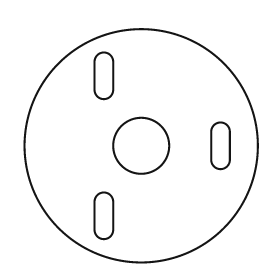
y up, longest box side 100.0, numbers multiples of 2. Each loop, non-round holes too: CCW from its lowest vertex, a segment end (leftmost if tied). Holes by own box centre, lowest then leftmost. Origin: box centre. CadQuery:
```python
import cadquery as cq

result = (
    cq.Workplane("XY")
    .moveTo(0.0, 0.0)
    .circle(50.0)
    .moveTo(-20.0, -36.0)
    .threePointArc((-16.0, -40.0), (-12.0, -36.0))
    .lineTo(-12.0, -24.0)
    .threePointArc((-16.0, -20.0), (-20.0, -24.0))
    .close()
    .moveTo(0.0, 0.0)
    .circle(12.0)
    .moveTo(30.0, -6.0)
    .threePointArc((34.0, -10.0), (38.0, -6.0))
    .lineTo(38.0, 6.0)
    .threePointArc((34.0, 10.0), (30.0, 6.0))
    .close()
    .moveTo(-20.0, 24.0)
    .threePointArc((-16.0, 20.0), (-12.0, 24.0))
    .lineTo(-12.0, 36.0)
    .threePointArc((-16.0, 40.0), (-20.0, 36.0))
    .close()
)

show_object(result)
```